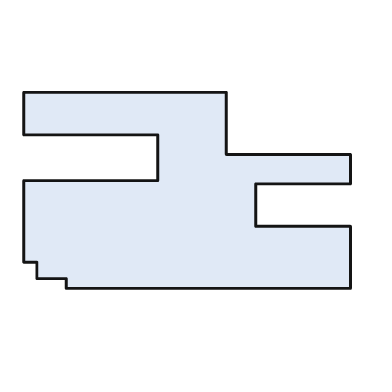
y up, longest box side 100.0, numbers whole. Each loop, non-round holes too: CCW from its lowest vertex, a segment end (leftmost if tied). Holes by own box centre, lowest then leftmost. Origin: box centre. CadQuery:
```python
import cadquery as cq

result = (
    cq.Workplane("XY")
    .moveTo(-37.0, -30.0)
    .lineTo(50.0, -30.0)
    .lineTo(50.0, -11.0)
    .lineTo(21.0, -11.0)
    .lineTo(21.0, 2.0)
    .lineTo(50.0, 2.0)
    .lineTo(50.0, 11.0)
    .lineTo(12.0, 11.0)
    .lineTo(12.0, 30.0)
    .lineTo(-50.0, 30.0)
    .lineTo(-50.0, 17.0)
    .lineTo(-9.0, 17.0)
    .lineTo(-9.0, 3.0)
    .lineTo(-50.0, 3.0)
    .lineTo(-50.0, -22.0)
    .lineTo(-46.0, -22.0)
    .lineTo(-46.0, -27.0)
    .lineTo(-37.0, -27.0)
    .close()
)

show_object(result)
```